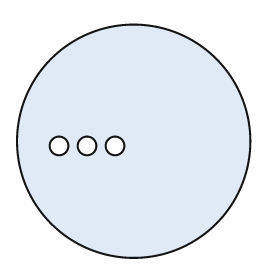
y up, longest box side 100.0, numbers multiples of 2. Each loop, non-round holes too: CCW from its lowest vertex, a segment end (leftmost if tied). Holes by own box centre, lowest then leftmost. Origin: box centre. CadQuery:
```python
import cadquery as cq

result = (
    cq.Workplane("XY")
    .moveTo(0.0, 0.0)
    .circle(50.0)
    .moveTo(-32.0, -2.0)
    .circle(4.0)
    .moveTo(-20.0, -2.0)
    .circle(4.0)
    .moveTo(-8.0, -2.0)
    .circle(4.0)
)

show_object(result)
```